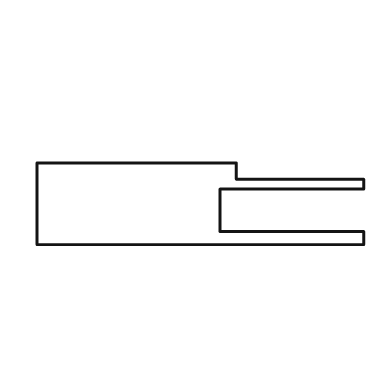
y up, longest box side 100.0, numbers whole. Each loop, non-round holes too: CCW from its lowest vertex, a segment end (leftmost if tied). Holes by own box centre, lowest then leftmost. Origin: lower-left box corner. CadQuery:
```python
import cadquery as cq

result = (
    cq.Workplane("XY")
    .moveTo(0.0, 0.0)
    .lineTo(100.0, 0.0)
    .lineTo(100.0, 4.0)
    .lineTo(56.0, 4.0)
    .lineTo(56.0, 17.0)
    .lineTo(100.0, 17.0)
    .lineTo(100.0, 20.0)
    .lineTo(61.0, 20.0)
    .lineTo(61.0, 25.0)
    .lineTo(0.0, 25.0)
    .close()
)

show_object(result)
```